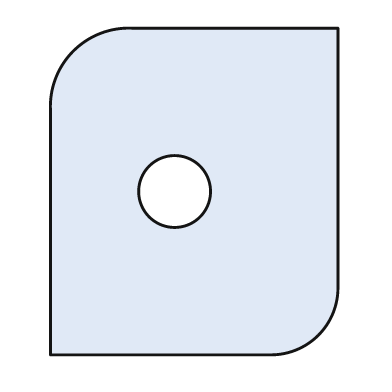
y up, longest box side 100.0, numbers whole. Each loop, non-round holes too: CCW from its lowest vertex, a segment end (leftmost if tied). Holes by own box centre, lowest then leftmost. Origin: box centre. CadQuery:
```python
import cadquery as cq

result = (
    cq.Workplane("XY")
    .moveTo(-44.0, -50.0)
    .lineTo(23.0, -50.0)
    .threePointArc((38.0, -44.0), (44.0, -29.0))
    .lineTo(44.0, 50.0)
    .lineTo(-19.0, 50.0)
    .threePointArc((-37.0, 43.0), (-44.0, 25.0))
    .close()
    .moveTo(-6.0, 0.0)
    .circle(11.0)
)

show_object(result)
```